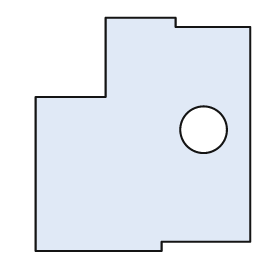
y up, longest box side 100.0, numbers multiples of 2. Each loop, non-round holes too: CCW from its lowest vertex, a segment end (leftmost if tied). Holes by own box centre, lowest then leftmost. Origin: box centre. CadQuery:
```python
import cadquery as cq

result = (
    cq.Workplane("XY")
    .moveTo(-46.0, -50.0)
    .lineTo(8.0, -50.0)
    .lineTo(8.0, -46.0)
    .lineTo(46.0, -46.0)
    .lineTo(46.0, 46.0)
    .lineTo(14.0, 46.0)
    .lineTo(14.0, 50.0)
    .lineTo(-16.0, 50.0)
    .lineTo(-16.0, 16.0)
    .lineTo(-46.0, 16.0)
    .close()
    .moveTo(26.0, 2.0)
    .circle(10.0)
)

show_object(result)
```